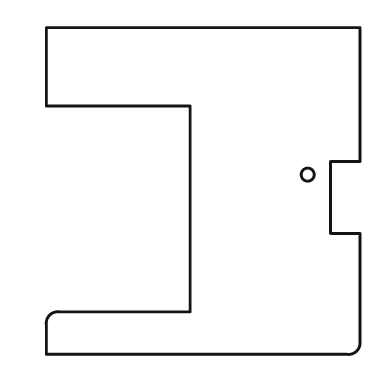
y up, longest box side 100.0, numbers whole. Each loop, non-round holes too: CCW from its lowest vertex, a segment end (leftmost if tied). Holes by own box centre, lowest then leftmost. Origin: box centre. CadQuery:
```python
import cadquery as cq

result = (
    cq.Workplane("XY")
    .moveTo(-48.0, -50.0)
    .lineTo(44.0, -50.0)
    .threePointArc((47.0, -49.0), (48.0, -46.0))
    .lineTo(48.0, -13.0)
    .lineTo(39.0, -13.0)
    .lineTo(39.0, 9.0)
    .lineTo(48.0, 9.0)
    .lineTo(48.0, 50.0)
    .lineTo(-48.0, 50.0)
    .lineTo(-48.0, 26.0)
    .lineTo(-4.0, 26.0)
    .lineTo(-4.0, -37.0)
    .lineTo(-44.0, -37.0)
    .threePointArc((-47.0, -38.0), (-48.0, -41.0))
    .close()
    .moveTo(32.0, 5.0)
    .circle(2.0)
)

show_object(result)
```